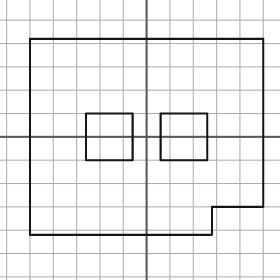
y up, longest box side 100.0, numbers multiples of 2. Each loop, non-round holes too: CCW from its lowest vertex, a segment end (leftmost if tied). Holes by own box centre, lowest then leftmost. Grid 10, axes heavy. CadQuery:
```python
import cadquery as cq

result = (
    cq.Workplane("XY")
    .moveTo(-50.0, -42.0)
    .lineTo(28.0, -42.0)
    .lineTo(28.0, -30.0)
    .lineTo(50.0, -30.0)
    .lineTo(50.0, 42.0)
    .lineTo(-50.0, 42.0)
    .close()
    .moveTo(-26.0, -10.0)
    .lineTo(-6.0, -10.0)
    .lineTo(-6.0, 10.0)
    .lineTo(-26.0, 10.0)
    .close()
    .moveTo(6.0, -10.0)
    .lineTo(26.0, -10.0)
    .lineTo(26.0, 10.0)
    .lineTo(6.0, 10.0)
    .close()
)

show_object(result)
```